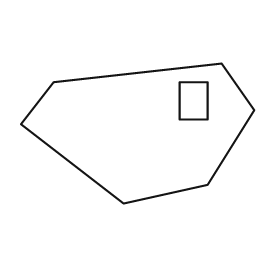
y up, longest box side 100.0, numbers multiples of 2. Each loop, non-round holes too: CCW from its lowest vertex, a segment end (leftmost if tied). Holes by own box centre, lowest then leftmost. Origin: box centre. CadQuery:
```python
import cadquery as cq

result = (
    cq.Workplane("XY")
    .moveTo(-6.0, -30.0)
    .lineTo(30.0, -22.0)
    .lineTo(50.0, 10.0)
    .lineTo(36.0, 30.0)
    .lineTo(-36.0, 22.0)
    .lineTo(-50.0, 4.0)
    .close()
    .moveTo(18.0, 6.0)
    .lineTo(30.0, 6.0)
    .lineTo(30.0, 22.0)
    .lineTo(18.0, 22.0)
    .close()
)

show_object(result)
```